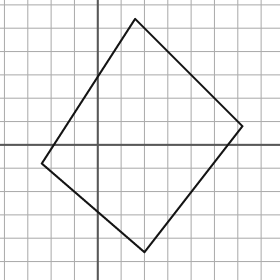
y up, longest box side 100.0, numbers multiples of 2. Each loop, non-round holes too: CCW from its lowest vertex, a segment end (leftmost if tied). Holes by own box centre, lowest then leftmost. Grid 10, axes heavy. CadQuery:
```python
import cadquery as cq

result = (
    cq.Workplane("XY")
    .moveTo(20.0, -46.0)
    .lineTo(62.0, 8.0)
    .lineTo(16.0, 54.0)
    .lineTo(-24.0, -8.0)
    .close()
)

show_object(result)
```